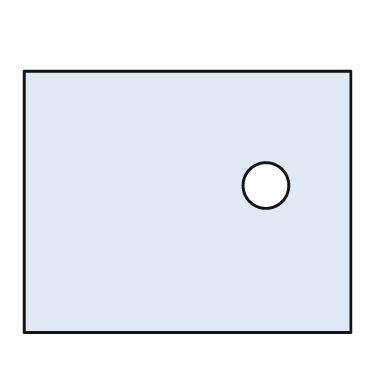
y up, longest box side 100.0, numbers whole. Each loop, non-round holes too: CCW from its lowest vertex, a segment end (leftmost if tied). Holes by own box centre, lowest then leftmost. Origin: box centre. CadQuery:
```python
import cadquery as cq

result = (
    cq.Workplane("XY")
    .moveTo(-50.0, -40.0)
    .lineTo(50.0, -40.0)
    .lineTo(50.0, 40.0)
    .lineTo(-50.0, 40.0)
    .close()
    .moveTo(24.0, 5.0)
    .circle(7.0)
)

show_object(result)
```